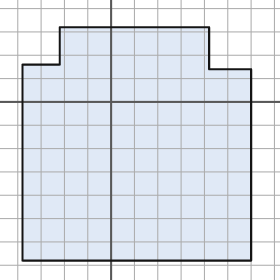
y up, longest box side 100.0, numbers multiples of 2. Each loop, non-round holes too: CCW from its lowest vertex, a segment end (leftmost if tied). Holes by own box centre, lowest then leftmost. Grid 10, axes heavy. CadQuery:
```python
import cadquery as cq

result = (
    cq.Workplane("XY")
    .moveTo(-38.0, -68.0)
    .lineTo(60.0, -68.0)
    .lineTo(60.0, 14.0)
    .lineTo(42.0, 14.0)
    .lineTo(42.0, 32.0)
    .lineTo(-22.0, 32.0)
    .lineTo(-22.0, 16.0)
    .lineTo(-38.0, 16.0)
    .close()
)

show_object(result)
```